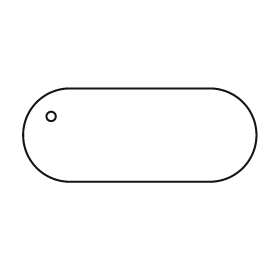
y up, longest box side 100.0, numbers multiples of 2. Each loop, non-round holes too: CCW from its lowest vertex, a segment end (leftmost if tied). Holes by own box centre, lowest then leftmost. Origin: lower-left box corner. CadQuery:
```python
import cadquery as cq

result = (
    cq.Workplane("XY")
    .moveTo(20.0, 0.0)
    .lineTo(80.0, 0.0)
    .threePointArc((100.0, 20.0), (80.0, 40.0))
    .lineTo(20.0, 40.0)
    .threePointArc((0.0, 20.0), (20.0, 0.0))
    .close()
    .moveTo(12.0, 28.0)
    .circle(2.0)
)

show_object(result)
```